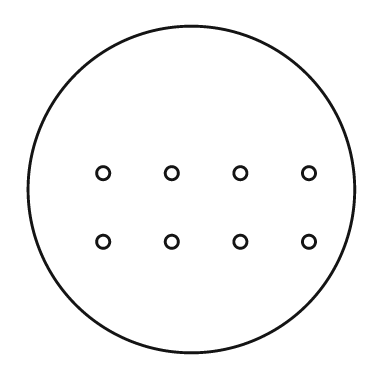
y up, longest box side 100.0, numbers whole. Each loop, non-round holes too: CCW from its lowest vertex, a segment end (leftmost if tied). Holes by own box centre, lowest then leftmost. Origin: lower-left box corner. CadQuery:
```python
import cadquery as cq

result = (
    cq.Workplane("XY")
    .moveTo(50.0, 50.0)
    .circle(50.0)
    .moveTo(23.0, 34.0)
    .circle(2.0)
    .moveTo(44.0, 34.0)
    .circle(2.0)
    .moveTo(65.0, 34.0)
    .circle(2.0)
    .moveTo(86.0, 34.0)
    .circle(2.0)
    .moveTo(23.0, 55.0)
    .circle(2.0)
    .moveTo(44.0, 55.0)
    .circle(2.0)
    .moveTo(65.0, 55.0)
    .circle(2.0)
    .moveTo(86.0, 55.0)
    .circle(2.0)
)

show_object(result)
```